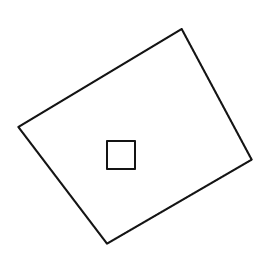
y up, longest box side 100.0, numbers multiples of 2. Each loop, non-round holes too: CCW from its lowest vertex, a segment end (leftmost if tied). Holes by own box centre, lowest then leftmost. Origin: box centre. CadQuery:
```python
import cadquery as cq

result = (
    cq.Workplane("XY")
    .moveTo(-12.0, -46.0)
    .lineTo(50.0, -10.0)
    .lineTo(20.0, 46.0)
    .lineTo(-50.0, 4.0)
    .close()
    .moveTo(-12.0, -14.0)
    .lineTo(0.0, -14.0)
    .lineTo(0.0, -2.0)
    .lineTo(-12.0, -2.0)
    .close()
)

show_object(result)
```